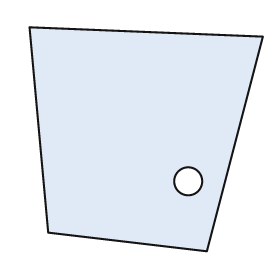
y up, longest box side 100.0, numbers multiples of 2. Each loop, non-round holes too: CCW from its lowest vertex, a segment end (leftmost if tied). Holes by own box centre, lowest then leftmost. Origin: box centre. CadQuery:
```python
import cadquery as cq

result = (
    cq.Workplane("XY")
    .moveTo(26.0, -48.0)
    .lineTo(50.0, 44.0)
    .lineTo(-50.0, 48.0)
    .lineTo(-42.0, -40.0)
    .close()
    .moveTo(18.0, -18.0)
    .circle(6.0)
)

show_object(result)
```